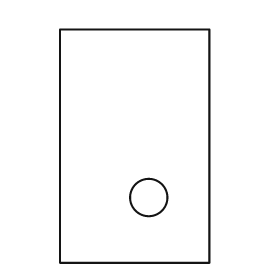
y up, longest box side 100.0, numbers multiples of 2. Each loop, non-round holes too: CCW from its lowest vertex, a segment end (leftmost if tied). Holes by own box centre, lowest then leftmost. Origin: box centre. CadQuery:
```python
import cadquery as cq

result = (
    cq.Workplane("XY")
    .moveTo(-32.0, -50.0)
    .lineTo(32.0, -50.0)
    .lineTo(32.0, 50.0)
    .lineTo(-32.0, 50.0)
    .close()
    .moveTo(6.0, -22.0)
    .circle(8.0)
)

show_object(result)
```